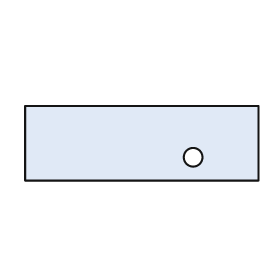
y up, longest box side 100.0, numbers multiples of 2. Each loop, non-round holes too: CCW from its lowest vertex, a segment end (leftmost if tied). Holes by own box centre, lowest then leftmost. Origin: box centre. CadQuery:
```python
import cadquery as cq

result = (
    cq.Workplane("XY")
    .moveTo(-50.0, -16.0)
    .lineTo(50.0, -16.0)
    .lineTo(50.0, 16.0)
    .lineTo(-50.0, 16.0)
    .close()
    .moveTo(22.0, -6.0)
    .circle(4.0)
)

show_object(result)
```